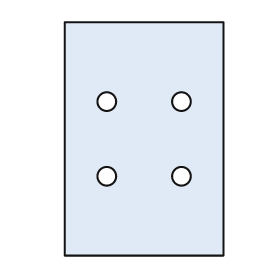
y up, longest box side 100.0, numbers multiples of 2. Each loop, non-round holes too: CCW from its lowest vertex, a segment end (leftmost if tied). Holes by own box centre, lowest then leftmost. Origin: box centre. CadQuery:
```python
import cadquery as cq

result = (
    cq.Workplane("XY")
    .moveTo(-34.0, -50.0)
    .lineTo(34.0, -50.0)
    .lineTo(34.0, 50.0)
    .lineTo(-34.0, 50.0)
    .close()
    .moveTo(-16.0, -16.0)
    .circle(4.0)
    .moveTo(16.0, -16.0)
    .circle(4.0)
    .moveTo(-16.0, 16.0)
    .circle(4.0)
    .moveTo(16.0, 16.0)
    .circle(4.0)
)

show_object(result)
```